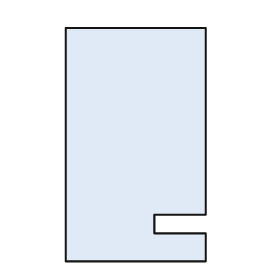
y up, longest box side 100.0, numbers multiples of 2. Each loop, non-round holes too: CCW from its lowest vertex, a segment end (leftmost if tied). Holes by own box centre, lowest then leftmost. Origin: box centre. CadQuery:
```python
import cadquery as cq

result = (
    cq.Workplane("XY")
    .moveTo(-30.0, -50.0)
    .lineTo(30.0, -50.0)
    .lineTo(30.0, -38.0)
    .lineTo(8.0, -38.0)
    .lineTo(8.0, -30.0)
    .lineTo(30.0, -30.0)
    .lineTo(30.0, 50.0)
    .lineTo(-30.0, 50.0)
    .close()
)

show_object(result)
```